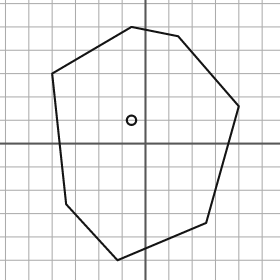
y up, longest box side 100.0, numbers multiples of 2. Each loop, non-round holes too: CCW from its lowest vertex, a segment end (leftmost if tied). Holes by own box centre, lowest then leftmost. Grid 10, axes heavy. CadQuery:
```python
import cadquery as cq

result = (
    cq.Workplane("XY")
    .moveTo(-12.0, -50.0)
    .lineTo(26.0, -34.0)
    .lineTo(40.0, 16.0)
    .lineTo(14.0, 46.0)
    .lineTo(-6.0, 50.0)
    .lineTo(-40.0, 30.0)
    .lineTo(-34.0, -26.0)
    .close()
    .moveTo(-6.0, 10.0)
    .circle(2.0)
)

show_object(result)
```